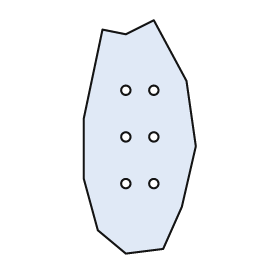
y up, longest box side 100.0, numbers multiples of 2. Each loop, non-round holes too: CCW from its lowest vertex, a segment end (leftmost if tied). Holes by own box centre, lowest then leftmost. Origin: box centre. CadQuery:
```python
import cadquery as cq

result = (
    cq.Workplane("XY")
    .moveTo(-6.0, -50.0)
    .lineTo(10.0, -48.0)
    .lineTo(18.0, -30.0)
    .lineTo(24.0, -4.0)
    .lineTo(20.0, 24.0)
    .lineTo(6.0, 50.0)
    .lineTo(-6.0, 44.0)
    .lineTo(-16.0, 46.0)
    .lineTo(-24.0, 8.0)
    .lineTo(-24.0, -18.0)
    .lineTo(-18.0, -40.0)
    .close()
    .moveTo(-6.0, -20.0)
    .circle(2.0)
    .moveTo(6.0, -20.0)
    .circle(2.0)
    .moveTo(-6.0, 0.0)
    .circle(2.0)
    .moveTo(6.0, 0.0)
    .circle(2.0)
    .moveTo(-6.0, 20.0)
    .circle(2.0)
    .moveTo(6.0, 20.0)
    .circle(2.0)
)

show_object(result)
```